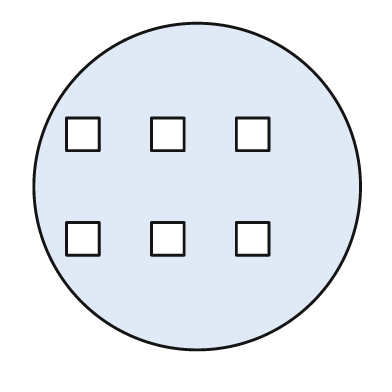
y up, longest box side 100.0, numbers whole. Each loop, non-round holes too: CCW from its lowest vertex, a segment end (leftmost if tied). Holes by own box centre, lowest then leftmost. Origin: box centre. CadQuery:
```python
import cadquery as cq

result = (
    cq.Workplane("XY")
    .moveTo(0.0, 0.0)
    .circle(50.0)
    .moveTo(-40.0, -21.0)
    .lineTo(-30.0, -21.0)
    .lineTo(-30.0, -11.0)
    .lineTo(-40.0, -11.0)
    .close()
    .moveTo(-14.0, -21.0)
    .lineTo(-4.0, -21.0)
    .lineTo(-4.0, -11.0)
    .lineTo(-14.0, -11.0)
    .close()
    .moveTo(12.0, -21.0)
    .lineTo(22.0, -21.0)
    .lineTo(22.0, -11.0)
    .lineTo(12.0, -11.0)
    .close()
    .moveTo(-40.0, 11.0)
    .lineTo(-30.0, 11.0)
    .lineTo(-30.0, 21.0)
    .lineTo(-40.0, 21.0)
    .close()
    .moveTo(-14.0, 11.0)
    .lineTo(-4.0, 11.0)
    .lineTo(-4.0, 21.0)
    .lineTo(-14.0, 21.0)
    .close()
    .moveTo(12.0, 11.0)
    .lineTo(22.0, 11.0)
    .lineTo(22.0, 21.0)
    .lineTo(12.0, 21.0)
    .close()
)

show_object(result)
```